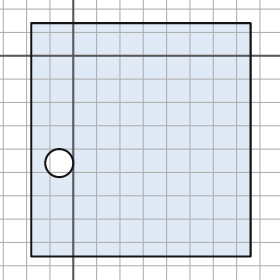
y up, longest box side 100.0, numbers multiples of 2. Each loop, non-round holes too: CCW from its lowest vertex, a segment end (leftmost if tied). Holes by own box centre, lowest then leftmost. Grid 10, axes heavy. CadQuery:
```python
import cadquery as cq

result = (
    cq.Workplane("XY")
    .moveTo(-18.0, -86.0)
    .lineTo(76.0, -86.0)
    .lineTo(76.0, 14.0)
    .lineTo(-18.0, 14.0)
    .close()
    .moveTo(-6.0, -46.0)
    .circle(6.0)
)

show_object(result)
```